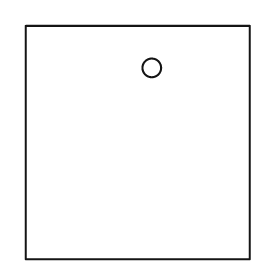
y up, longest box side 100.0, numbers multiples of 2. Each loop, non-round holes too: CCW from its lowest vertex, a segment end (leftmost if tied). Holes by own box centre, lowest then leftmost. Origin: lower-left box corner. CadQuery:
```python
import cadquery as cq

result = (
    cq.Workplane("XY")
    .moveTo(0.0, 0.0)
    .lineTo(96.0, 0.0)
    .lineTo(96.0, 100.0)
    .lineTo(0.0, 100.0)
    .close()
    .moveTo(54.0, 82.0)
    .circle(4.0)
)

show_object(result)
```